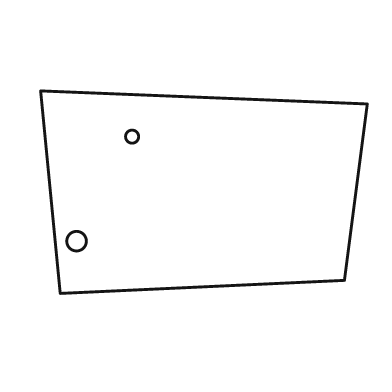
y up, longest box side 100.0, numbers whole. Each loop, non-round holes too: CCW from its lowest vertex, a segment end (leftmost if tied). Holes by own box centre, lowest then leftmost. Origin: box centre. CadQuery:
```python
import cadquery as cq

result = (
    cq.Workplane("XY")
    .moveTo(-44.0, -31.0)
    .lineTo(43.0, -27.0)
    .lineTo(50.0, 27.0)
    .lineTo(-50.0, 31.0)
    .close()
    .moveTo(-39.0, -15.0)
    .circle(3.0)
    .moveTo(-22.0, 17.0)
    .circle(2.0)
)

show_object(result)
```